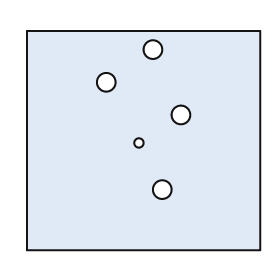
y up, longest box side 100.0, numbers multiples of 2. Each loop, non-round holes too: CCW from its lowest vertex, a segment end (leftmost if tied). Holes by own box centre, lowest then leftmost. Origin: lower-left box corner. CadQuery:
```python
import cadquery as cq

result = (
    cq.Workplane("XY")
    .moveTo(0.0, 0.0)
    .lineTo(100.0, 0.0)
    .lineTo(100.0, 94.0)
    .lineTo(0.0, 94.0)
    .close()
    .moveTo(58.0, 26.0)
    .circle(4.0)
    .moveTo(48.0, 46.0)
    .circle(2.0)
    .moveTo(66.0, 58.0)
    .circle(4.0)
    .moveTo(34.0, 72.0)
    .circle(4.0)
    .moveTo(54.0, 86.0)
    .circle(4.0)
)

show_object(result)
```